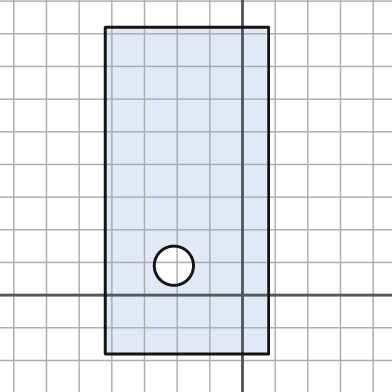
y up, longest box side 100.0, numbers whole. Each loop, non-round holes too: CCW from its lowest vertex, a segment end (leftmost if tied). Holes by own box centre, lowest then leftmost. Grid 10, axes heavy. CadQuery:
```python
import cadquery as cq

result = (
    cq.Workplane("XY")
    .moveTo(-42.0, -18.0)
    .lineTo(8.0, -18.0)
    .lineTo(8.0, 82.0)
    .lineTo(-42.0, 82.0)
    .close()
    .moveTo(-21.0, 9.0)
    .circle(6.0)
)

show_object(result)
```